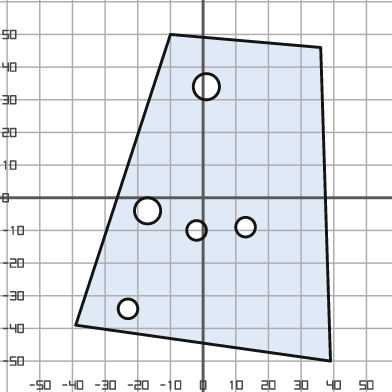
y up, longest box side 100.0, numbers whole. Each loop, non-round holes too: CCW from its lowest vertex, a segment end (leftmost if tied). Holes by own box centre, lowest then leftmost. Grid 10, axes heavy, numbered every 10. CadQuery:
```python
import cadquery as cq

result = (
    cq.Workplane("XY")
    .moveTo(39.0, -50.0)
    .lineTo(36.0, 46.0)
    .lineTo(-10.0, 50.0)
    .lineTo(-39.0, -39.0)
    .close()
    .moveTo(-23.0, -34.0)
    .circle(3.0)
    .moveTo(-2.0, -10.0)
    .circle(3.0)
    .moveTo(13.0, -9.0)
    .circle(3.0)
    .moveTo(-17.0, -4.0)
    .circle(4.0)
    .moveTo(1.0, 34.0)
    .circle(4.0)
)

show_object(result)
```